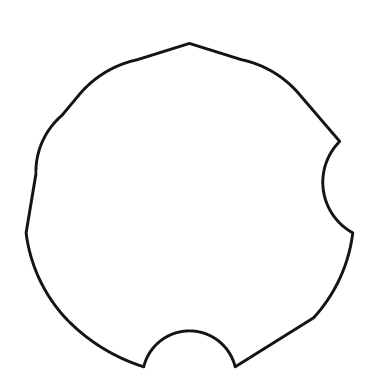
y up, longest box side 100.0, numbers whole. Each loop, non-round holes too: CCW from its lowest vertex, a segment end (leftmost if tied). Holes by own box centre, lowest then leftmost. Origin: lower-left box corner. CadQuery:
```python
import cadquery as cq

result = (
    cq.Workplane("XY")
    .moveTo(36.0, 0.0)
    .threePointArc((50.0, 11.0), (64.0, 0.0))
    .lineTo(88.0, 15.0)
    .threePointArc((96.0, 27.0), (100.0, 41.0))
    .threePointArc((91.0, 54.0), (96.0, 69.0))
    .lineTo(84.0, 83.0)
    .threePointArc((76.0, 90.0), (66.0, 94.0))
    .lineTo(50.0, 99.0)
    .lineTo(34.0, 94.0)
    .threePointArc((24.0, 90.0), (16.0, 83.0))
    .lineTo(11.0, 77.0)
    .threePointArc((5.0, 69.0), (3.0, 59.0))
    .lineTo(0.0, 41.0)
    .threePointArc((4.0, 27.0), (12.0, 15.0))
    .threePointArc((23.0, 6.0), (36.0, 0.0))
    .close()
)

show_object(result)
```